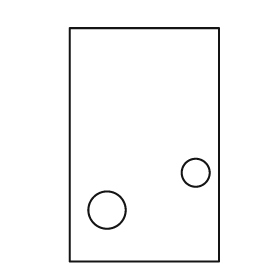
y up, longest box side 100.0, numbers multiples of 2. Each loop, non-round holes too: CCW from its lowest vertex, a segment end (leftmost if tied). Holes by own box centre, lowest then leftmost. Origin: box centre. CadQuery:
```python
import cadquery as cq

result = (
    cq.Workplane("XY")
    .moveTo(-32.0, -50.0)
    .lineTo(32.0, -50.0)
    .lineTo(32.0, 50.0)
    .lineTo(-32.0, 50.0)
    .close()
    .moveTo(-16.0, -28.0)
    .circle(8.0)
    .moveTo(22.0, -12.0)
    .circle(6.0)
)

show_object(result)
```